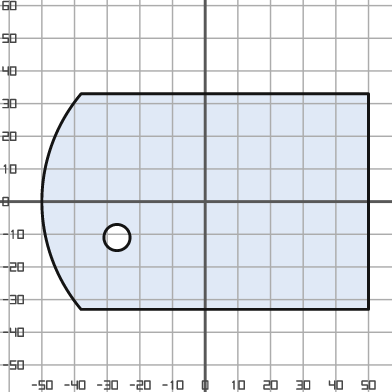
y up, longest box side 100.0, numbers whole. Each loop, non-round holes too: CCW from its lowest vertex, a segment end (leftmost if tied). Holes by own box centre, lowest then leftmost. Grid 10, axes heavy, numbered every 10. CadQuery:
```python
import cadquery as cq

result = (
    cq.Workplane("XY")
    .moveTo(-38.0, -33.0)
    .lineTo(50.0, -33.0)
    .lineTo(50.0, 33.0)
    .lineTo(-38.0, 33.0)
    .threePointArc((-50.0, 0.0), (-38.0, -33.0))
    .close()
    .moveTo(-27.0, -11.0)
    .circle(4.0)
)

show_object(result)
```